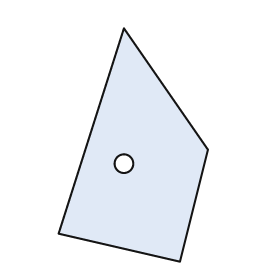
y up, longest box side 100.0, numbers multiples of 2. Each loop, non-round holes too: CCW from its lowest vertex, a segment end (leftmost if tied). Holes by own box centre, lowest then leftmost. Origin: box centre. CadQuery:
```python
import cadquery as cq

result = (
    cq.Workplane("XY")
    .moveTo(20.0, -50.0)
    .lineTo(32.0, -2.0)
    .lineTo(-4.0, 50.0)
    .lineTo(-32.0, -38.0)
    .close()
    .moveTo(-4.0, -8.0)
    .circle(4.0)
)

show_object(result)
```